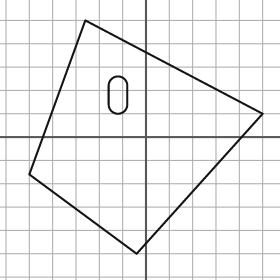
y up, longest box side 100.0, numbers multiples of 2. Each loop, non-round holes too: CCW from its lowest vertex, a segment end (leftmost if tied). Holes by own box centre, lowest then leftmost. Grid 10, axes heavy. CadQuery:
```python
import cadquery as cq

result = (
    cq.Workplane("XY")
    .moveTo(-4.0, -50.0)
    .lineTo(50.0, 10.0)
    .lineTo(-26.0, 50.0)
    .lineTo(-50.0, -16.0)
    .close()
    .moveTo(-16.0, 14.0)
    .threePointArc((-12.0, 10.0), (-8.0, 14.0))
    .lineTo(-8.0, 22.0)
    .threePointArc((-12.0, 26.0), (-16.0, 22.0))
    .close()
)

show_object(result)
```